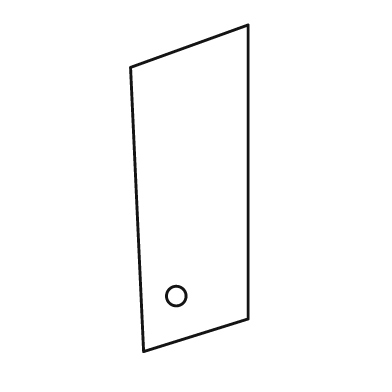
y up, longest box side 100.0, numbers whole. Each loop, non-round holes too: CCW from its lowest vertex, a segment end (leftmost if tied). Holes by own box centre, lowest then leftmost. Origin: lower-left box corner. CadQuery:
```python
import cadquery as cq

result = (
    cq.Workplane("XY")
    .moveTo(4.0, 0.0)
    .lineTo(36.0, 10.0)
    .lineTo(36.0, 100.0)
    .lineTo(0.0, 87.0)
    .close()
    .moveTo(14.0, 17.0)
    .circle(3.0)
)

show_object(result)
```